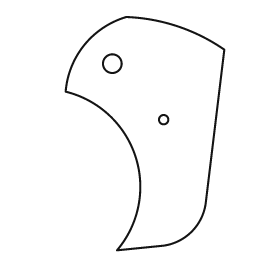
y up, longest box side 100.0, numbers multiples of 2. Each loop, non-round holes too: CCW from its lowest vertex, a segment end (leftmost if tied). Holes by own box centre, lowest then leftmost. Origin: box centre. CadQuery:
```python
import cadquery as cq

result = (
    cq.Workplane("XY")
    .moveTo(-12.0, -50.0)
    .lineTo(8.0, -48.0)
    .threePointArc((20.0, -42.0), (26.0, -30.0))
    .lineTo(34.0, 36.0)
    .threePointArc((14.0, 46.0), (-8.0, 50.0))
    .threePointArc((-26.0, 38.0), (-34.0, 18.0))
    .threePointArc((-4.0, -10.0), (-12.0, -50.0))
    .close()
    .moveTo(8.0, 6.0)
    .circle(2.0)
    .moveTo(-14.0, 30.0)
    .circle(4.0)
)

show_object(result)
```